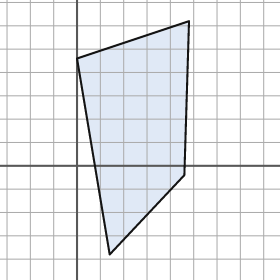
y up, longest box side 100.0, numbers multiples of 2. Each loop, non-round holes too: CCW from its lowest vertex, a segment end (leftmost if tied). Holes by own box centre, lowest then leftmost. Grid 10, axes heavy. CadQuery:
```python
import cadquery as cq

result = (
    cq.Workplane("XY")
    .moveTo(14.0, -38.0)
    .lineTo(46.0, -4.0)
    .lineTo(48.0, 62.0)
    .lineTo(0.0, 46.0)
    .close()
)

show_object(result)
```